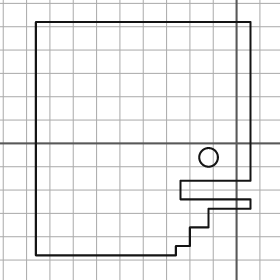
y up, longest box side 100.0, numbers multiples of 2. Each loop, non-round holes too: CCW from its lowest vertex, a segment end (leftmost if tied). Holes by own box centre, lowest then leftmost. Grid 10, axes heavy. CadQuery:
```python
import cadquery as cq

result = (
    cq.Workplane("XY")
    .moveTo(-86.0, -48.0)
    .lineTo(-26.0, -48.0)
    .lineTo(-26.0, -44.0)
    .lineTo(-20.0, -44.0)
    .lineTo(-20.0, -36.0)
    .lineTo(-12.0, -36.0)
    .lineTo(-12.0, -28.0)
    .lineTo(6.0, -28.0)
    .lineTo(6.0, -24.0)
    .lineTo(-24.0, -24.0)
    .lineTo(-24.0, -16.0)
    .lineTo(6.0, -16.0)
    .lineTo(6.0, 52.0)
    .lineTo(-86.0, 52.0)
    .close()
    .moveTo(-12.0, -6.0)
    .circle(4.0)
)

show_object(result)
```